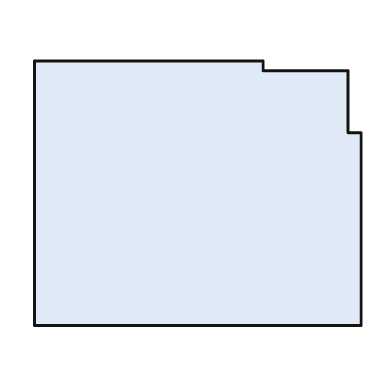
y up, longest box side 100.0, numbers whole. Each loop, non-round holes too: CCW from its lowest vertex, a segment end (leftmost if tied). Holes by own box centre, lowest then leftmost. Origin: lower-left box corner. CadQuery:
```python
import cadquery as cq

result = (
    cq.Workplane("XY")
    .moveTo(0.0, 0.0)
    .lineTo(100.0, 0.0)
    .lineTo(100.0, 59.0)
    .lineTo(96.0, 59.0)
    .lineTo(96.0, 78.0)
    .lineTo(70.0, 78.0)
    .lineTo(70.0, 81.0)
    .lineTo(0.0, 81.0)
    .close()
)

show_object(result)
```